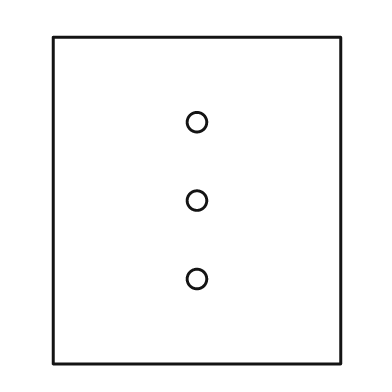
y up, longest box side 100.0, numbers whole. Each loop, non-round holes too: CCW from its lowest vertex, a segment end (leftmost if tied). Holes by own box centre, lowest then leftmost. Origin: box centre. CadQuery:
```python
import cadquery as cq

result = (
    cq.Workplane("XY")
    .moveTo(-44.0, -50.0)
    .lineTo(44.0, -50.0)
    .lineTo(44.0, 50.0)
    .lineTo(-44.0, 50.0)
    .close()
    .moveTo(0.0, -24.0)
    .circle(3.0)
    .moveTo(0.0, 0.0)
    .circle(3.0)
    .moveTo(0.0, 24.0)
    .circle(3.0)
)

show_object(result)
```